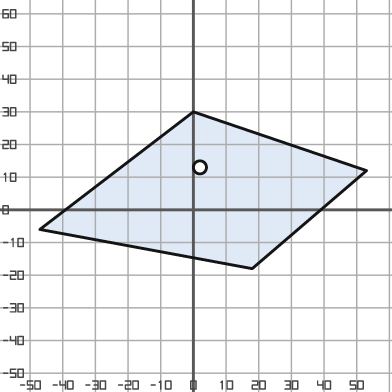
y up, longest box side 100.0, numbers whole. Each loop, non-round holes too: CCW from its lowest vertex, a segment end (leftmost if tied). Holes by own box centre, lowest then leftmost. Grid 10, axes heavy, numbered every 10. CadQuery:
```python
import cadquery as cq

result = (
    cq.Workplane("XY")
    .moveTo(18.0, -18.0)
    .lineTo(53.0, 12.0)
    .lineTo(0.0, 30.0)
    .lineTo(-47.0, -6.0)
    .close()
    .moveTo(2.0, 13.0)
    .circle(2.0)
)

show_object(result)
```